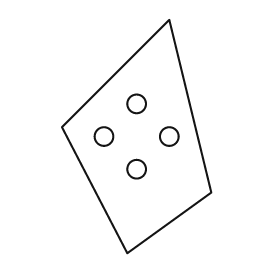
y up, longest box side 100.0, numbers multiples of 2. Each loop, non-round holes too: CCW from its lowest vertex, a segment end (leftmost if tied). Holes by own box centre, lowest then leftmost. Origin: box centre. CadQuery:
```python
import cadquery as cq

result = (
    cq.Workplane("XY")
    .moveTo(-4.0, -50.0)
    .lineTo(32.0, -24.0)
    .lineTo(14.0, 50.0)
    .lineTo(-32.0, 4.0)
    .close()
    .moveTo(0.0, -14.0)
    .circle(4.0)
    .moveTo(-14.0, 0.0)
    .circle(4.0)
    .moveTo(14.0, 0.0)
    .circle(4.0)
    .moveTo(0.0, 14.0)
    .circle(4.0)
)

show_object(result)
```